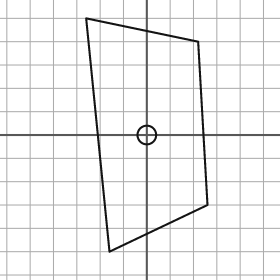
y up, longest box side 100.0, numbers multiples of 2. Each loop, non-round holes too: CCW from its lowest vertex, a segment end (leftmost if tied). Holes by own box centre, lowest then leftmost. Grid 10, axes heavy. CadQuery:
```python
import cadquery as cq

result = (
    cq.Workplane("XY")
    .moveTo(-16.0, -50.0)
    .lineTo(26.0, -30.0)
    .lineTo(22.0, 40.0)
    .lineTo(-26.0, 50.0)
    .close()
    .moveTo(0.0, 0.0)
    .circle(4.0)
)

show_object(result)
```